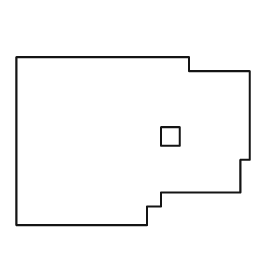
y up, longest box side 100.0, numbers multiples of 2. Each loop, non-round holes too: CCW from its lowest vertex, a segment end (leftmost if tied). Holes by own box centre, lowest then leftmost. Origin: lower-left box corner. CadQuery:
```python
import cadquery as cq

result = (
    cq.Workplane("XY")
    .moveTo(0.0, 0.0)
    .lineTo(56.0, 0.0)
    .lineTo(56.0, 8.0)
    .lineTo(62.0, 8.0)
    .lineTo(62.0, 14.0)
    .lineTo(96.0, 14.0)
    .lineTo(96.0, 28.0)
    .lineTo(100.0, 28.0)
    .lineTo(100.0, 66.0)
    .lineTo(74.0, 66.0)
    .lineTo(74.0, 72.0)
    .lineTo(0.0, 72.0)
    .close()
    .moveTo(62.0, 34.0)
    .lineTo(70.0, 34.0)
    .lineTo(70.0, 42.0)
    .lineTo(62.0, 42.0)
    .close()
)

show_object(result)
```